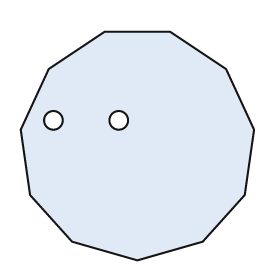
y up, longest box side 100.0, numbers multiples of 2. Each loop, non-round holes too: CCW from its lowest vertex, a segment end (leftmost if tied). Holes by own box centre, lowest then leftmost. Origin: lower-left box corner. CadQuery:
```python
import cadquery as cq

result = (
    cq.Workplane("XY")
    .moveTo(50.0, 0.0)
    .lineTo(78.0, 8.0)
    .lineTo(96.0, 28.0)
    .lineTo(100.0, 56.0)
    .lineTo(88.0, 82.0)
    .lineTo(64.0, 98.0)
    .lineTo(36.0, 98.0)
    .lineTo(12.0, 82.0)
    .lineTo(0.0, 56.0)
    .lineTo(4.0, 28.0)
    .lineTo(22.0, 8.0)
    .close()
    .moveTo(14.0, 60.0)
    .circle(4.0)
    .moveTo(42.0, 60.0)
    .circle(4.0)
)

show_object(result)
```